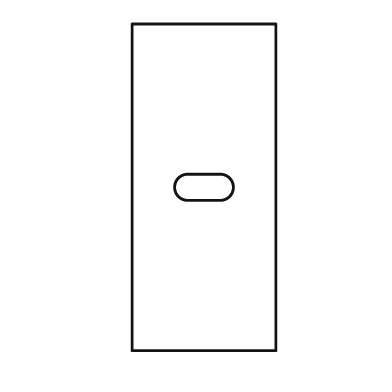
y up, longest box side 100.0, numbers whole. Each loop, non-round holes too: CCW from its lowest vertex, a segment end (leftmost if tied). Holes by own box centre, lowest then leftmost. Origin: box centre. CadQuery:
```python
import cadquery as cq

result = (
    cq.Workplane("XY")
    .moveTo(-22.0, -50.0)
    .lineTo(22.0, -50.0)
    .lineTo(22.0, 50.0)
    .lineTo(-22.0, 50.0)
    .close()
    .moveTo(-5.0, -4.0)
    .lineTo(5.0, -4.0)
    .threePointArc((9.0, 0.0), (5.0, 4.0))
    .lineTo(-5.0, 4.0)
    .threePointArc((-9.0, 0.0), (-5.0, -4.0))
    .close()
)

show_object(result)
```